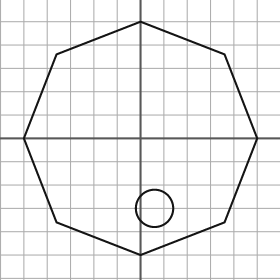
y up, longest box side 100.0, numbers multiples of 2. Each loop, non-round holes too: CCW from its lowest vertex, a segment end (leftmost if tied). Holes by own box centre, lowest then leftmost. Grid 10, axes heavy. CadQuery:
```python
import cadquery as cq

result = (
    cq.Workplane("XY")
    .moveTo(0.0, -50.0)
    .lineTo(36.0, -36.0)
    .lineTo(50.0, 0.0)
    .lineTo(36.0, 36.0)
    .lineTo(0.0, 50.0)
    .lineTo(-36.0, 36.0)
    .lineTo(-50.0, 0.0)
    .lineTo(-36.0, -36.0)
    .close()
    .moveTo(6.0, -30.0)
    .circle(8.0)
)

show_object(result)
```